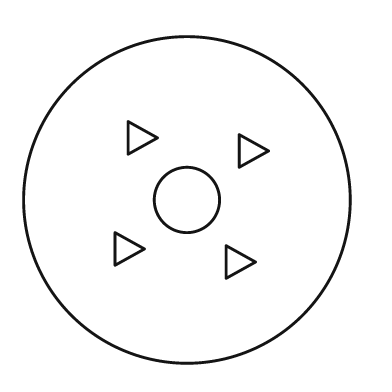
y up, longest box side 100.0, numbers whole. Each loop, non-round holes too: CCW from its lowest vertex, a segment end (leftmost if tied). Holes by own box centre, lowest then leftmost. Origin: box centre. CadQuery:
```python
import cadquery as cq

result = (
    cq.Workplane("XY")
    .moveTo(0.0, 0.0)
    .circle(50.0)
    .moveTo(12.0, -24.0)
    .lineTo(21.0, -19.0)
    .lineTo(12.0, -14.0)
    .close()
    .moveTo(-22.0, -20.0)
    .lineTo(-13.0, -15.0)
    .lineTo(-22.0, -10.0)
    .close()
    .moveTo(0.0, 0.0)
    .circle(10.0)
    .moveTo(16.0, 10.0)
    .lineTo(25.0, 15.0)
    .lineTo(16.0, 20.0)
    .close()
    .moveTo(-18.0, 14.0)
    .lineTo(-9.0, 19.0)
    .lineTo(-18.0, 24.0)
    .close()
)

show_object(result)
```